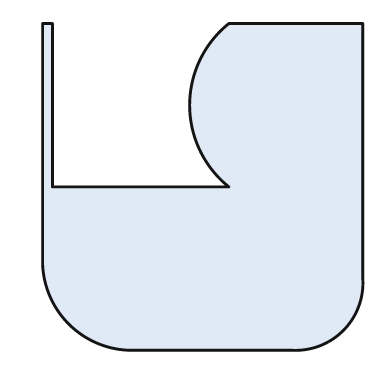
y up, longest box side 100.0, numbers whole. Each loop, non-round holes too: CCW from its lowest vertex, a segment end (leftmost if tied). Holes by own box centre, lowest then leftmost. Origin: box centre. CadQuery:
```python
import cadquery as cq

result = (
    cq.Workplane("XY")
    .moveTo(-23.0, -50.0)
    .lineTo(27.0, -50.0)
    .threePointArc((43.0, -44.0), (49.0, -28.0))
    .lineTo(49.0, 50.0)
    .lineTo(8.0, 50.0)
    .threePointArc((-4.0, 25.0), (8.0, 0.0))
    .lineTo(-46.0, 0.0)
    .lineTo(-46.0, 50.0)
    .lineTo(-49.0, 50.0)
    .lineTo(-49.0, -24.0)
    .threePointArc((-41.0, -42.0), (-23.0, -50.0))
    .close()
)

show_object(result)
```